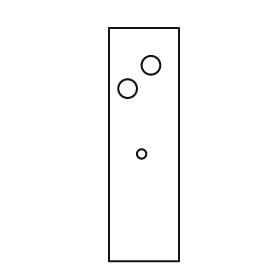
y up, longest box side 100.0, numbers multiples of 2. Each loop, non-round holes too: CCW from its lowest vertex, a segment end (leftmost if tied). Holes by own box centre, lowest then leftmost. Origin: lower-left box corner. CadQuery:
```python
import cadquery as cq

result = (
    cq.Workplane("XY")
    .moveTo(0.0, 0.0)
    .lineTo(30.0, 0.0)
    .lineTo(30.0, 100.0)
    .lineTo(0.0, 100.0)
    .close()
    .moveTo(14.0, 46.0)
    .circle(2.0)
    .moveTo(8.0, 74.0)
    .circle(4.0)
    .moveTo(18.0, 84.0)
    .circle(4.0)
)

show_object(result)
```